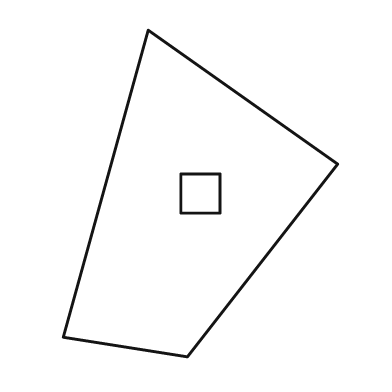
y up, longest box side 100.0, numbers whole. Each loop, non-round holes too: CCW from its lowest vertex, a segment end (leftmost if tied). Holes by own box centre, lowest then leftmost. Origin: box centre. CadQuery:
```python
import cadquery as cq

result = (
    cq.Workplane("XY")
    .moveTo(-4.0, -50.0)
    .lineTo(42.0, 9.0)
    .lineTo(-16.0, 50.0)
    .lineTo(-42.0, -44.0)
    .close()
    .moveTo(-6.0, -6.0)
    .lineTo(6.0, -6.0)
    .lineTo(6.0, 6.0)
    .lineTo(-6.0, 6.0)
    .close()
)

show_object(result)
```